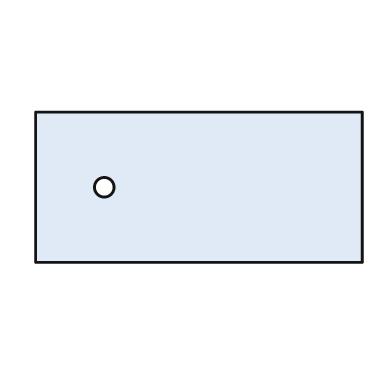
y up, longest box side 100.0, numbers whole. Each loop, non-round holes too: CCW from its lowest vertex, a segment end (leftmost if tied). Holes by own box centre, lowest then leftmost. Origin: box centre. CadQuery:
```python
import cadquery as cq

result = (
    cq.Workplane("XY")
    .moveTo(-50.0, -23.0)
    .lineTo(50.0, -23.0)
    .lineTo(50.0, 23.0)
    .lineTo(-50.0, 23.0)
    .close()
    .moveTo(-29.0, 0.0)
    .circle(3.0)
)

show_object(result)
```